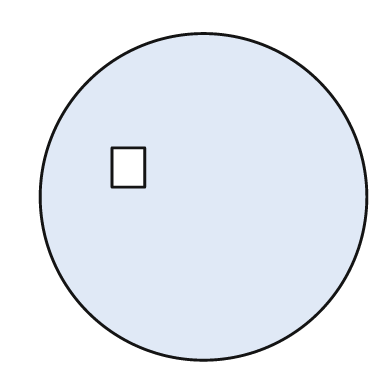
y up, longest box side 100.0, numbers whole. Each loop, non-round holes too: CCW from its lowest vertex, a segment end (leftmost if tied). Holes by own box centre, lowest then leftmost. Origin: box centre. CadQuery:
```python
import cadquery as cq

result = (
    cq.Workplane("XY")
    .moveTo(0.0, 0.0)
    .circle(50.0)
    .moveTo(-28.0, 3.0)
    .lineTo(-18.0, 3.0)
    .lineTo(-18.0, 15.0)
    .lineTo(-28.0, 15.0)
    .close()
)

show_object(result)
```